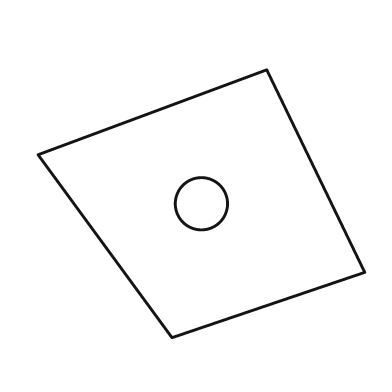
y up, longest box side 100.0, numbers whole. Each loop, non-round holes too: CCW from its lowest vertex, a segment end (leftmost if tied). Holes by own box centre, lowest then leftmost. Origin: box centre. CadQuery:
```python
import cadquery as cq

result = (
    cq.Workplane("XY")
    .moveTo(-9.0, -41.0)
    .lineTo(50.0, -21.0)
    .lineTo(20.0, 41.0)
    .lineTo(-50.0, 15.0)
    .close()
    .moveTo(0.0, 0.0)
    .circle(8.0)
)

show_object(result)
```